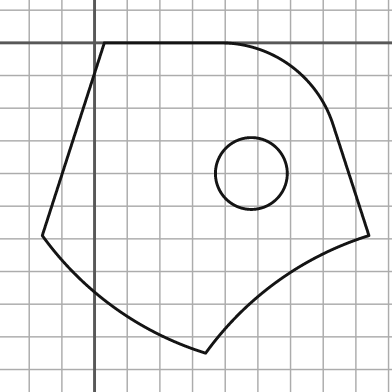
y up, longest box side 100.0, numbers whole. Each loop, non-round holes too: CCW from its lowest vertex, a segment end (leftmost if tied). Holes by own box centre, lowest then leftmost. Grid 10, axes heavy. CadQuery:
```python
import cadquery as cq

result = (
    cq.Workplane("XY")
    .moveTo(34.0, -95.0)
    .threePointArc((56.0, -73.0), (84.0, -59.0))
    .lineTo(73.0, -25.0)
    .threePointArc((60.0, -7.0), (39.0, 0.0))
    .lineTo(3.0, 0.0)
    .lineTo(-16.0, -59.0)
    .threePointArc((6.0, -81.0), (34.0, -95.0))
    .close()
    .moveTo(48.0, -40.0)
    .circle(11.0)
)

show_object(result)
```